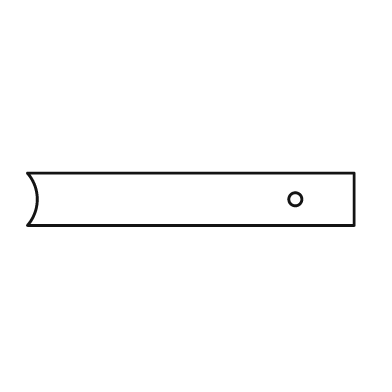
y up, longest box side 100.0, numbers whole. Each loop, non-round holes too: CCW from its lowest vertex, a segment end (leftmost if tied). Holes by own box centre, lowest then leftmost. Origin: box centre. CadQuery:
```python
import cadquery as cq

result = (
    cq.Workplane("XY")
    .moveTo(-50.0, -8.0)
    .lineTo(50.0, -8.0)
    .lineTo(50.0, 8.0)
    .lineTo(-50.0, 8.0)
    .threePointArc((-47.0, 0.0), (-50.0, -8.0))
    .close()
    .moveTo(32.0, 0.0)
    .circle(2.0)
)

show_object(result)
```